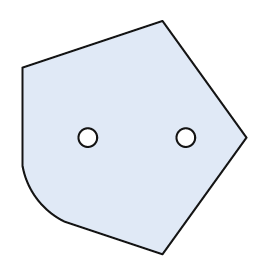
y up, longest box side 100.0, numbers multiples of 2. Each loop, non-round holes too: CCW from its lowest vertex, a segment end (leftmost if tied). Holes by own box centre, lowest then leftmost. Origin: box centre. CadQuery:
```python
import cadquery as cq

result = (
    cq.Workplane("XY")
    .moveTo(12.0, -50.0)
    .lineTo(48.0, 0.0)
    .lineTo(12.0, 50.0)
    .lineTo(-48.0, 30.0)
    .lineTo(-48.0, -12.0)
    .threePointArc((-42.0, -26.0), (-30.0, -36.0))
    .close()
    .moveTo(-20.0, 0.0)
    .circle(4.0)
    .moveTo(22.0, 0.0)
    .circle(4.0)
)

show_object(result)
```